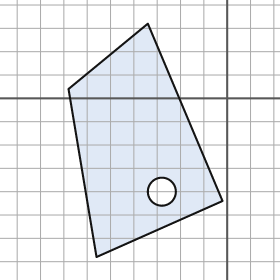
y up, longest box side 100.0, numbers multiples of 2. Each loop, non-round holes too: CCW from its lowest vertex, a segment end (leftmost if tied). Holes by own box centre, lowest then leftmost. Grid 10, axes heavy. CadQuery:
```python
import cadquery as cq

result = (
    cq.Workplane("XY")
    .moveTo(-56.0, -68.0)
    .lineTo(-2.0, -44.0)
    .lineTo(-34.0, 32.0)
    .lineTo(-68.0, 4.0)
    .close()
    .moveTo(-28.0, -40.0)
    .circle(6.0)
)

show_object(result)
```